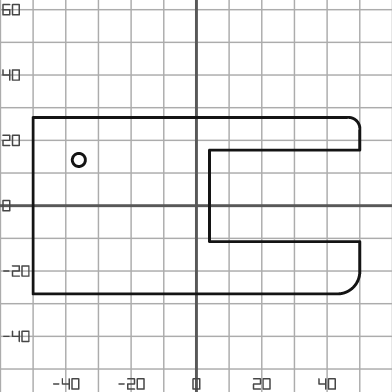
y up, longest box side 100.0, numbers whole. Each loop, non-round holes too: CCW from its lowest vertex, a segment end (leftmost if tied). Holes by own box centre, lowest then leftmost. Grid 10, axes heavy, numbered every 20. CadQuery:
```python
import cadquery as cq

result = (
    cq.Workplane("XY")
    .moveTo(-50.0, -27.0)
    .lineTo(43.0, -27.0)
    .threePointArc((48.0, -25.0), (50.0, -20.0))
    .lineTo(50.0, -11.0)
    .lineTo(4.0, -11.0)
    .lineTo(4.0, 17.0)
    .lineTo(50.0, 17.0)
    .lineTo(50.0, 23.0)
    .threePointArc((49.0, 26.0), (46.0, 27.0))
    .lineTo(-50.0, 27.0)
    .close()
    .moveTo(-36.0, 14.0)
    .circle(2.0)
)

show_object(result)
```